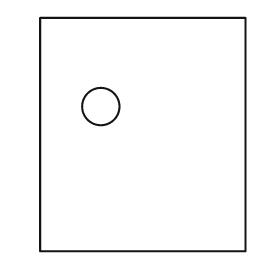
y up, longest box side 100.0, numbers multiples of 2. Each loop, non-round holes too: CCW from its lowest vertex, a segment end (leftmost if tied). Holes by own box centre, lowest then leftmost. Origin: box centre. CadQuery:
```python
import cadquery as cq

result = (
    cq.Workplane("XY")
    .moveTo(-44.0, -50.0)
    .lineTo(44.0, -50.0)
    .lineTo(44.0, 50.0)
    .lineTo(-44.0, 50.0)
    .close()
    .moveTo(-18.0, 12.0)
    .circle(8.0)
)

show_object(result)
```